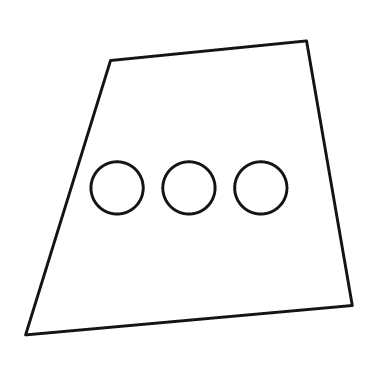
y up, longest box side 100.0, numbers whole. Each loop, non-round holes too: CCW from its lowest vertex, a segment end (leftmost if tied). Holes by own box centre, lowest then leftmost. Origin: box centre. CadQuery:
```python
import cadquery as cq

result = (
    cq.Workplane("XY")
    .moveTo(-50.0, -45.0)
    .lineTo(50.0, -36.0)
    .lineTo(36.0, 45.0)
    .lineTo(-24.0, 39.0)
    .close()
    .moveTo(-22.0, 0.0)
    .circle(8.0)
    .moveTo(0.0, 0.0)
    .circle(8.0)
    .moveTo(22.0, 0.0)
    .circle(8.0)
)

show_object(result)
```